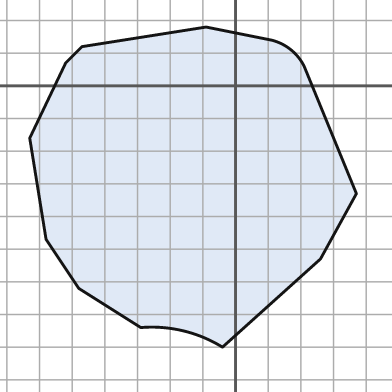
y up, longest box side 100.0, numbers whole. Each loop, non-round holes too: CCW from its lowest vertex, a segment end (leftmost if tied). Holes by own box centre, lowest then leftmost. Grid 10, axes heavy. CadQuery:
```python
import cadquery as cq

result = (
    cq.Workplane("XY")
    .moveTo(-4.0, -80.0)
    .lineTo(26.0, -53.0)
    .lineTo(37.0, -33.0)
    .lineTo(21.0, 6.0)
    .threePointArc((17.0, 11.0), (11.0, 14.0))
    .lineTo(-9.0, 18.0)
    .lineTo(-47.0, 12.0)
    .lineTo(-52.0, 7.0)
    .lineTo(-63.0, -16.0)
    .lineTo(-58.0, -47.0)
    .lineTo(-48.0, -62.0)
    .lineTo(-29.0, -74.0)
    .threePointArc((-16.0, -75.0), (-4.0, -80.0))
    .close()
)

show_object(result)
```